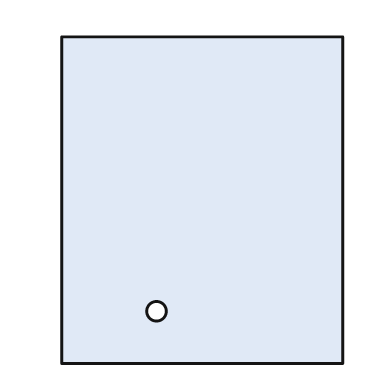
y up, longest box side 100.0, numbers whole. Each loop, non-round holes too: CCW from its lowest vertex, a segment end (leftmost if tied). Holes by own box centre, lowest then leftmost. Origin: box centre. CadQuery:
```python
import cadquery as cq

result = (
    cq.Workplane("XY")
    .moveTo(-43.0, -50.0)
    .lineTo(43.0, -50.0)
    .lineTo(43.0, 50.0)
    .lineTo(-43.0, 50.0)
    .close()
    .moveTo(-14.0, -34.0)
    .circle(3.0)
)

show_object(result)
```